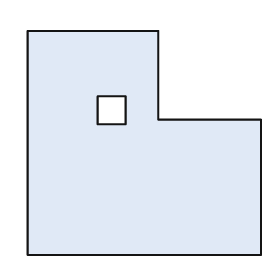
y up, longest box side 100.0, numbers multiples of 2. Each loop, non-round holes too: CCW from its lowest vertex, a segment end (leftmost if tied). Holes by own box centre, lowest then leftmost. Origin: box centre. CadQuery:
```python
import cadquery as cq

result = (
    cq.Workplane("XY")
    .moveTo(-50.0, -48.0)
    .lineTo(50.0, -48.0)
    .lineTo(50.0, 10.0)
    .lineTo(6.0, 10.0)
    .lineTo(6.0, 48.0)
    .lineTo(-50.0, 48.0)
    .close()
    .moveTo(-20.0, 8.0)
    .lineTo(-8.0, 8.0)
    .lineTo(-8.0, 20.0)
    .lineTo(-20.0, 20.0)
    .close()
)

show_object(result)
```